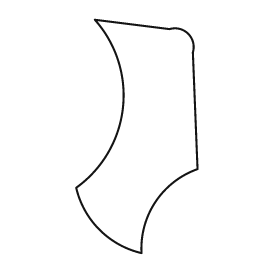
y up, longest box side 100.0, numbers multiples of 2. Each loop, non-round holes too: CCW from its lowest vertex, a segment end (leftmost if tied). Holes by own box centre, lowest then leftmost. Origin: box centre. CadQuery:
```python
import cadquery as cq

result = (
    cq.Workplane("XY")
    .moveTo(2.0, -50.0)
    .threePointArc((8.0, -28.0), (26.0, -14.0))
    .lineTo(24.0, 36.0)
    .threePointArc((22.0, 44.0), (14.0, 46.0))
    .lineTo(-18.0, 50.0)
    .threePointArc((-6.0, 12.0), (-26.0, -22.0))
    .threePointArc((-16.0, -40.0), (2.0, -50.0))
    .close()
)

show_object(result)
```